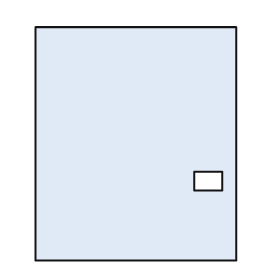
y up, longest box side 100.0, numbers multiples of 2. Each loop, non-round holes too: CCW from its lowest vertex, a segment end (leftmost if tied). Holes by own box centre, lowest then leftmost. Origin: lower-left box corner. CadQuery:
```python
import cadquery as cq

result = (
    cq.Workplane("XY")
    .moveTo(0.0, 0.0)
    .lineTo(86.0, 0.0)
    .lineTo(86.0, 100.0)
    .lineTo(0.0, 100.0)
    .close()
    .moveTo(68.0, 30.0)
    .lineTo(80.0, 30.0)
    .lineTo(80.0, 38.0)
    .lineTo(68.0, 38.0)
    .close()
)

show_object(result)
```